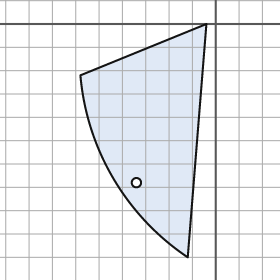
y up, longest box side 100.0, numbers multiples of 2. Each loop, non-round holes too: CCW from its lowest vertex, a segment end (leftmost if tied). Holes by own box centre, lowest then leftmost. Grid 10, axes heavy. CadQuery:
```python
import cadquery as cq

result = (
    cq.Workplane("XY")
    .moveTo(-12.0, -100.0)
    .lineTo(-4.0, 0.0)
    .lineTo(-58.0, -22.0)
    .threePointArc((-44.0, -66.0), (-12.0, -100.0))
    .close()
    .moveTo(-34.0, -68.0)
    .circle(2.0)
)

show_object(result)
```